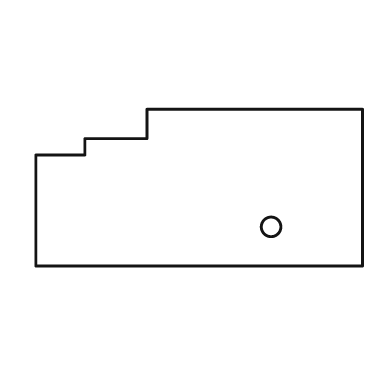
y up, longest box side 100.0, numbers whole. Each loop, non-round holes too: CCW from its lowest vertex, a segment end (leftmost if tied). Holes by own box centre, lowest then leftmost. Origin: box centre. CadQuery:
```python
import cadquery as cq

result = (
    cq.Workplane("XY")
    .moveTo(-50.0, -24.0)
    .lineTo(50.0, -24.0)
    .lineTo(50.0, 24.0)
    .lineTo(-16.0, 24.0)
    .lineTo(-16.0, 15.0)
    .lineTo(-35.0, 15.0)
    .lineTo(-35.0, 10.0)
    .lineTo(-50.0, 10.0)
    .close()
    .moveTo(22.0, -12.0)
    .circle(3.0)
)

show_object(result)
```